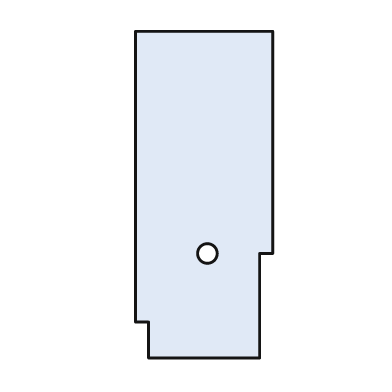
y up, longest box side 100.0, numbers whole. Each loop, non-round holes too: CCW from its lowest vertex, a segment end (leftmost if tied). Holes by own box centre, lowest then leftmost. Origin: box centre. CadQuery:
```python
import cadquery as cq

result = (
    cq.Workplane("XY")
    .moveTo(-17.0, -50.0)
    .lineTo(17.0, -50.0)
    .lineTo(17.0, -18.0)
    .lineTo(21.0, -18.0)
    .lineTo(21.0, 50.0)
    .lineTo(-21.0, 50.0)
    .lineTo(-21.0, -39.0)
    .lineTo(-17.0, -39.0)
    .close()
    .moveTo(1.0, -18.0)
    .circle(3.0)
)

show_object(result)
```